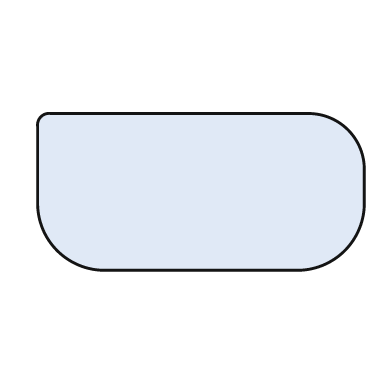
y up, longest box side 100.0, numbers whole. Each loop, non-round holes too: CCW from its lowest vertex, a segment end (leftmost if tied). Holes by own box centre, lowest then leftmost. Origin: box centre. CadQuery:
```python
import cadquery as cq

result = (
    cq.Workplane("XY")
    .moveTo(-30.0, -24.0)
    .lineTo(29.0, -24.0)
    .threePointArc((44.0, -18.0), (50.0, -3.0))
    .lineTo(50.0, 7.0)
    .threePointArc((45.0, 19.0), (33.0, 24.0))
    .lineTo(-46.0, 24.0)
    .threePointArc((-49.0, 23.0), (-50.0, 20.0))
    .lineTo(-50.0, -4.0)
    .threePointArc((-44.0, -18.0), (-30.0, -24.0))
    .close()
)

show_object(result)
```